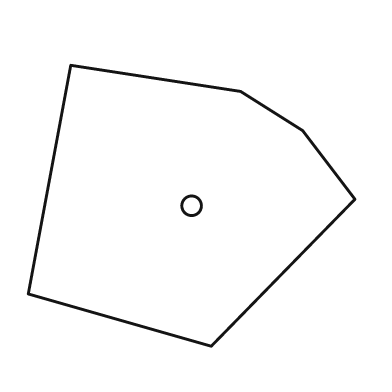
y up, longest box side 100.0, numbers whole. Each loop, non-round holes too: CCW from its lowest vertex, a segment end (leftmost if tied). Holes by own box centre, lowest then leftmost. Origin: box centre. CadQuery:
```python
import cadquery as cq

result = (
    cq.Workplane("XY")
    .moveTo(6.0, -43.0)
    .lineTo(50.0, 2.0)
    .lineTo(34.0, 23.0)
    .lineTo(15.0, 35.0)
    .lineTo(-37.0, 43.0)
    .lineTo(-50.0, -27.0)
    .close()
    .moveTo(0.0, 0.0)
    .circle(3.0)
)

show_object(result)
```